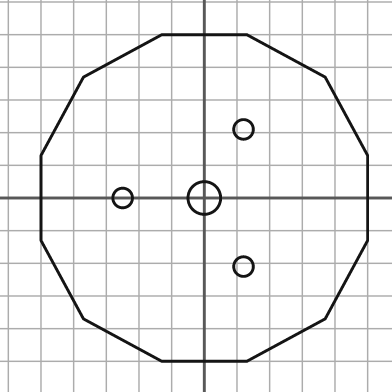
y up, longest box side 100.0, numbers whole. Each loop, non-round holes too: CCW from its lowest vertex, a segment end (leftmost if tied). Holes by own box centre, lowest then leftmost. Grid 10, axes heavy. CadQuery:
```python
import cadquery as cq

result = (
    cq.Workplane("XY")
    .moveTo(-13.0, -50.0)
    .lineTo(13.0, -50.0)
    .lineTo(37.0, -37.0)
    .lineTo(50.0, -13.0)
    .lineTo(50.0, 13.0)
    .lineTo(37.0, 37.0)
    .lineTo(13.0, 50.0)
    .lineTo(-13.0, 50.0)
    .lineTo(-37.0, 37.0)
    .lineTo(-50.0, 13.0)
    .lineTo(-50.0, -13.0)
    .lineTo(-37.0, -37.0)
    .close()
    .moveTo(12.0, -21.0)
    .circle(3.0)
    .moveTo(-25.0, 0.0)
    .circle(3.0)
    .moveTo(0.0, 0.0)
    .circle(5.0)
    .moveTo(12.0, 21.0)
    .circle(3.0)
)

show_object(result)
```